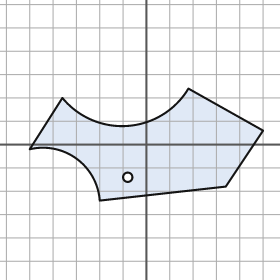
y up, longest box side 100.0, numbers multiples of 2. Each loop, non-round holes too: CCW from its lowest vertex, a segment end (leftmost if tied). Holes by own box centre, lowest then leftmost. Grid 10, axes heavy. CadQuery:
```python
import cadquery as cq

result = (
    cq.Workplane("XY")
    .moveTo(-20.0, -24.0)
    .lineTo(34.0, -18.0)
    .lineTo(50.0, 6.0)
    .lineTo(18.0, 24.0)
    .threePointArc((-8.0, 8.0), (-36.0, 20.0))
    .lineTo(-50.0, -2.0)
    .threePointArc((-30.0, -6.0), (-20.0, -24.0))
    .close()
    .moveTo(-8.0, -14.0)
    .circle(2.0)
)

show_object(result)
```